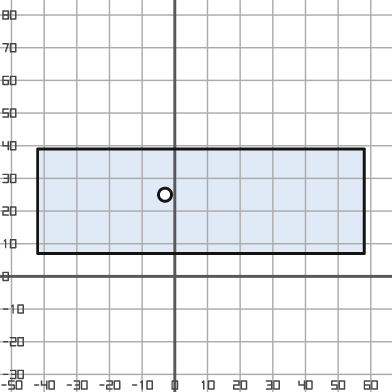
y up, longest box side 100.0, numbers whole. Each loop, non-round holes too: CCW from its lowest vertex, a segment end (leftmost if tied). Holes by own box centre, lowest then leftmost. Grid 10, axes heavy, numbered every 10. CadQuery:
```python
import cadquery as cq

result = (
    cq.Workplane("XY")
    .moveTo(-42.0, 7.0)
    .lineTo(58.0, 7.0)
    .lineTo(58.0, 39.0)
    .lineTo(-42.0, 39.0)
    .close()
    .moveTo(-3.0, 25.0)
    .circle(2.0)
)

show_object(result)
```